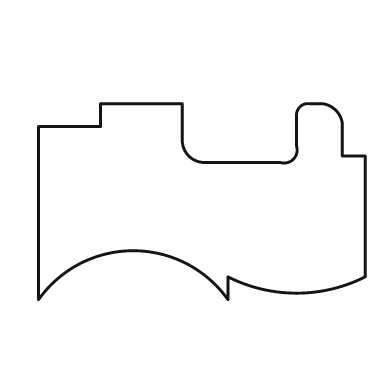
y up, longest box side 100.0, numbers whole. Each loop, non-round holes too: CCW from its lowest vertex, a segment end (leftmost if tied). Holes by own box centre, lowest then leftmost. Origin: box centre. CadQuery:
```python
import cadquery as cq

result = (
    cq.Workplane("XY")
    .moveTo(-50.0, -30.0)
    .threePointArc((-21.0, -15.0), (8.0, -30.0))
    .lineTo(8.0, -23.0)
    .threePointArc((29.0, -28.0), (50.0, -23.0))
    .lineTo(50.0, 14.0)
    .lineTo(43.0, 14.0)
    .lineTo(43.0, 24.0)
    .threePointArc((41.0, 28.0), (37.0, 30.0))
    .lineTo(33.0, 30.0)
    .threePointArc((30.0, 29.0), (29.0, 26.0))
    .lineTo(29.0, 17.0)
    .threePointArc((28.0, 13.0), (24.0, 12.0))
    .lineTo(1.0, 12.0)
    .threePointArc((-4.0, 14.0), (-6.0, 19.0))
    .lineTo(-6.0, 30.0)
    .lineTo(-31.0, 30.0)
    .lineTo(-31.0, 23.0)
    .lineTo(-50.0, 23.0)
    .close()
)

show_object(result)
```